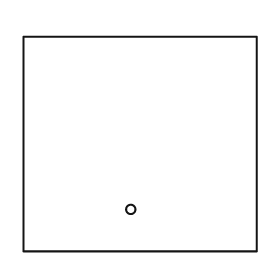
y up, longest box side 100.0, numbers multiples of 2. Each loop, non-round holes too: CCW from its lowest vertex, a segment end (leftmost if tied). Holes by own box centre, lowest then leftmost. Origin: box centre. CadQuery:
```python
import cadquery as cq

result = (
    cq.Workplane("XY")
    .moveTo(-50.0, -46.0)
    .lineTo(50.0, -46.0)
    .lineTo(50.0, 46.0)
    .lineTo(-50.0, 46.0)
    .close()
    .moveTo(-4.0, -28.0)
    .circle(2.0)
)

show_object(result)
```